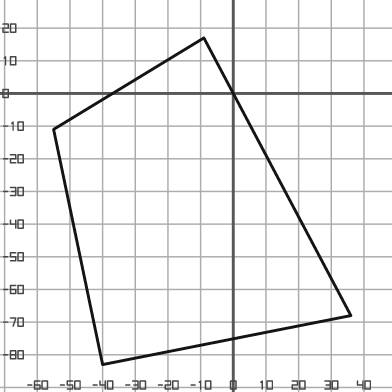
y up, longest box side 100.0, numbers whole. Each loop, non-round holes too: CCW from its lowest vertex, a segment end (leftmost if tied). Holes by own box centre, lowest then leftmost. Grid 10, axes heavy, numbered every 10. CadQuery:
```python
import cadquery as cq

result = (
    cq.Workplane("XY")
    .moveTo(-40.0, -83.0)
    .lineTo(36.0, -68.0)
    .lineTo(-9.0, 17.0)
    .lineTo(-55.0, -11.0)
    .close()
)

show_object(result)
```